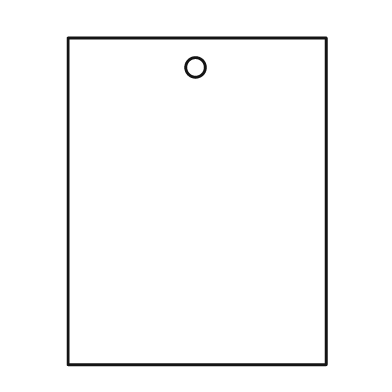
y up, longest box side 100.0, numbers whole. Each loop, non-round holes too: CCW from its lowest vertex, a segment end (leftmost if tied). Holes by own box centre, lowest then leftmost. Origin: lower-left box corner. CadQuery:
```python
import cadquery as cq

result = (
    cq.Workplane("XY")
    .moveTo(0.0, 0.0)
    .lineTo(79.0, 0.0)
    .lineTo(79.0, 100.0)
    .lineTo(0.0, 100.0)
    .close()
    .moveTo(39.0, 91.0)
    .circle(3.0)
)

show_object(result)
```